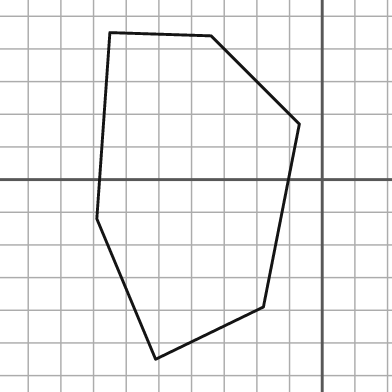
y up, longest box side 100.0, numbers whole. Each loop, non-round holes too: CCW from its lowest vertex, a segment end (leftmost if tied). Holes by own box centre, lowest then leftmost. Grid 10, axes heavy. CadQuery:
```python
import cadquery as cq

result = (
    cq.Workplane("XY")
    .moveTo(-51.0, -55.0)
    .lineTo(-18.0, -39.0)
    .lineTo(-7.0, 17.0)
    .lineTo(-34.0, 44.0)
    .lineTo(-65.0, 45.0)
    .lineTo(-69.0, -12.0)
    .close()
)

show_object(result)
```